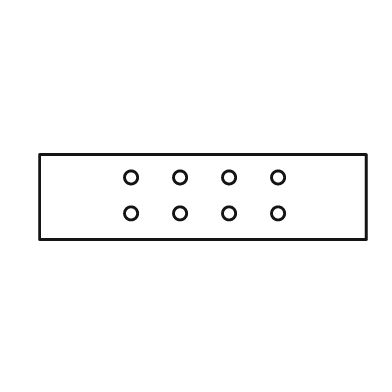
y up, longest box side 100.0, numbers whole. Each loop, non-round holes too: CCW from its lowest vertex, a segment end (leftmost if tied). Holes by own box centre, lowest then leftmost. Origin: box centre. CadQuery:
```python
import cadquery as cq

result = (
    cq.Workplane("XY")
    .moveTo(-50.0, -13.0)
    .lineTo(50.0, -13.0)
    .lineTo(50.0, 13.0)
    .lineTo(-50.0, 13.0)
    .close()
    .moveTo(-22.0, -5.0)
    .circle(2.0)
    .moveTo(-7.0, -5.0)
    .circle(2.0)
    .moveTo(8.0, -5.0)
    .circle(2.0)
    .moveTo(23.0, -5.0)
    .circle(2.0)
    .moveTo(-22.0, 6.0)
    .circle(2.0)
    .moveTo(-7.0, 6.0)
    .circle(2.0)
    .moveTo(8.0, 6.0)
    .circle(2.0)
    .moveTo(23.0, 6.0)
    .circle(2.0)
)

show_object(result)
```